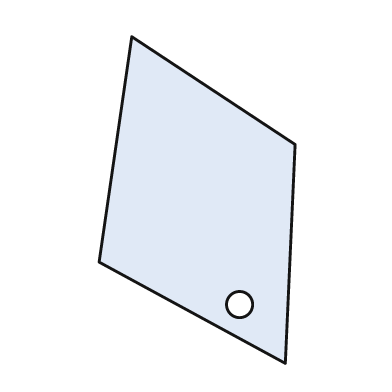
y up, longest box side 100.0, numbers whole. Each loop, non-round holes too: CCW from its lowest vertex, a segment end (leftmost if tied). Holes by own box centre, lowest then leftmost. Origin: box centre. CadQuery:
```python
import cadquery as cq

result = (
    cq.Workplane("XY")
    .moveTo(27.0, -50.0)
    .lineTo(30.0, 17.0)
    .lineTo(-20.0, 50.0)
    .lineTo(-30.0, -19.0)
    .close()
    .moveTo(13.0, -32.0)
    .circle(4.0)
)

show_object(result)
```